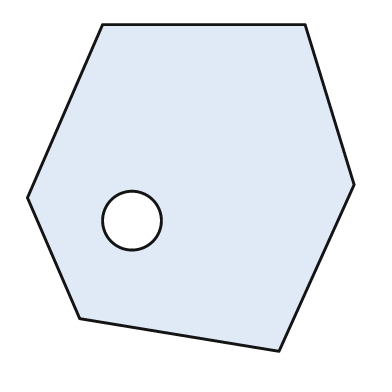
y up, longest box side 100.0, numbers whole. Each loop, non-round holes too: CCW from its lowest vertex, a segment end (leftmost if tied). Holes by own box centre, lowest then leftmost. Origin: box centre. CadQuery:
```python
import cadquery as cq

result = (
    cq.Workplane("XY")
    .moveTo(27.0, -50.0)
    .lineTo(50.0, 1.0)
    .lineTo(35.0, 50.0)
    .lineTo(-27.0, 50.0)
    .lineTo(-50.0, -3.0)
    .lineTo(-34.0, -40.0)
    .close()
    .moveTo(-18.0, -10.0)
    .circle(9.0)
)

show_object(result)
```